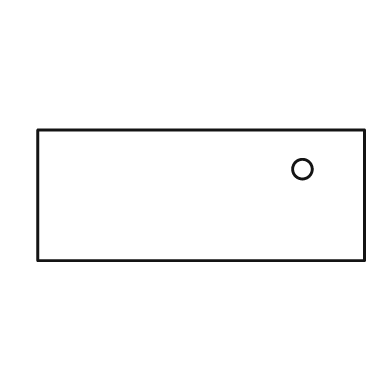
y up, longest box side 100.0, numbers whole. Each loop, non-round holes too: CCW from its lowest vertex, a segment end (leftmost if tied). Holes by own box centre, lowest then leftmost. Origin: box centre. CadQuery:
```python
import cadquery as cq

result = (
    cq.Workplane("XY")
    .moveTo(-50.0, -20.0)
    .lineTo(50.0, -20.0)
    .lineTo(50.0, 20.0)
    .lineTo(-50.0, 20.0)
    .close()
    .moveTo(31.0, 8.0)
    .circle(3.0)
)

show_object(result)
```